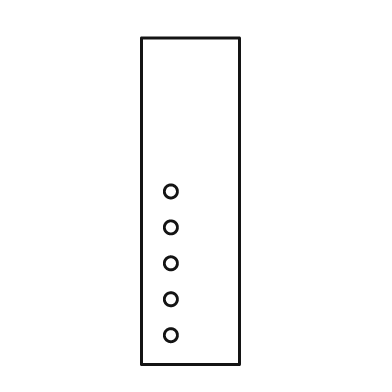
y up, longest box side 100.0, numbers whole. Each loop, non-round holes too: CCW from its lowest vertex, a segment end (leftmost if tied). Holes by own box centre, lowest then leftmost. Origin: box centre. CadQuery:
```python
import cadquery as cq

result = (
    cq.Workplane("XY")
    .moveTo(-15.0, -50.0)
    .lineTo(15.0, -50.0)
    .lineTo(15.0, 50.0)
    .lineTo(-15.0, 50.0)
    .close()
    .moveTo(-6.0, -41.0)
    .circle(2.0)
    .moveTo(-6.0, -30.0)
    .circle(2.0)
    .moveTo(-6.0, -19.0)
    .circle(2.0)
    .moveTo(-6.0, -8.0)
    .circle(2.0)
    .moveTo(-6.0, 3.0)
    .circle(2.0)
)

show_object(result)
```